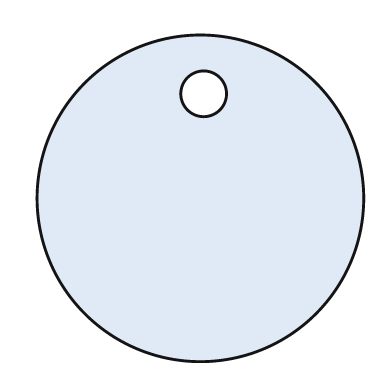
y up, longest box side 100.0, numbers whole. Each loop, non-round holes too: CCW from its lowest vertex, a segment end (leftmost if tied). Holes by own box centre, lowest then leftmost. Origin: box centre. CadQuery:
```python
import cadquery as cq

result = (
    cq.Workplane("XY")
    .moveTo(0.0, 0.0)
    .circle(50.0)
    .moveTo(1.0, 32.0)
    .circle(7.0)
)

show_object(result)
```